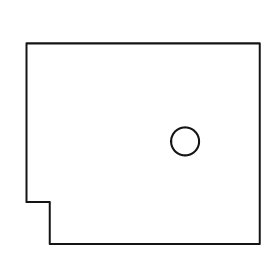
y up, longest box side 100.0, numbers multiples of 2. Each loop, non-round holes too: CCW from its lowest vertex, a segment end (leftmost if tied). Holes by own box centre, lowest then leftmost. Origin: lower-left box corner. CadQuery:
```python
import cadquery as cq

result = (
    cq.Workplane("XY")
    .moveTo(10.0, 0.0)
    .lineTo(100.0, 0.0)
    .lineTo(100.0, 86.0)
    .lineTo(0.0, 86.0)
    .lineTo(0.0, 18.0)
    .lineTo(10.0, 18.0)
    .close()
    .moveTo(68.0, 44.0)
    .circle(6.0)
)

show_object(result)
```